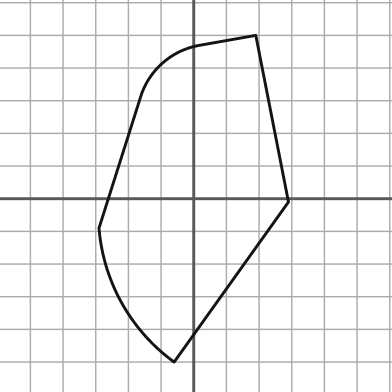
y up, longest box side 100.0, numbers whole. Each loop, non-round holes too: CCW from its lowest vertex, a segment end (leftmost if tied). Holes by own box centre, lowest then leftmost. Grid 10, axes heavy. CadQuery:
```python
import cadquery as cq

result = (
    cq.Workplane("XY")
    .moveTo(-6.0, -50.0)
    .lineTo(29.0, -1.0)
    .lineTo(19.0, 50.0)
    .lineTo(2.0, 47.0)
    .threePointArc((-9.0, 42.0), (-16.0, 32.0))
    .lineTo(-29.0, -9.0)
    .threePointArc((-22.0, -32.0), (-6.0, -50.0))
    .close()
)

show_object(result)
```